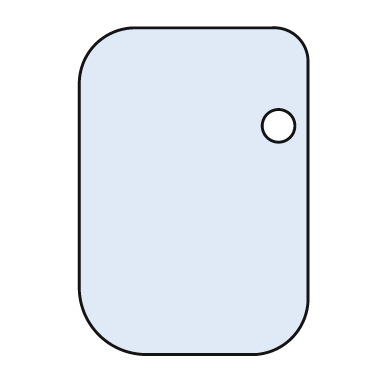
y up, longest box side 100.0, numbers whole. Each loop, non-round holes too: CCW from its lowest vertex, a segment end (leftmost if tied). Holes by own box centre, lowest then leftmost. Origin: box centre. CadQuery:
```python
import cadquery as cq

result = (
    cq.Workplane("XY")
    .moveTo(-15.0, -50.0)
    .lineTo(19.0, -50.0)
    .threePointArc((30.0, -45.0), (35.0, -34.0))
    .lineTo(35.0, 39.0)
    .threePointArc((32.0, 47.0), (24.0, 50.0))
    .lineTo(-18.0, 50.0)
    .threePointArc((-30.0, 45.0), (-35.0, 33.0))
    .lineTo(-35.0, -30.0)
    .threePointArc((-29.0, -44.0), (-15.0, -50.0))
    .close()
    .moveTo(26.0, 20.0)
    .circle(5.0)
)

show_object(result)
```